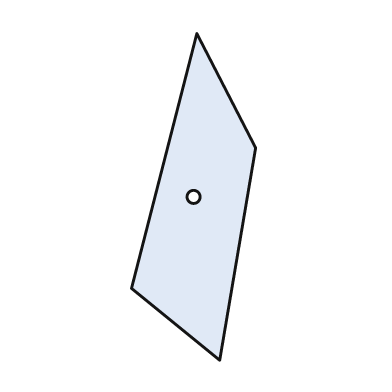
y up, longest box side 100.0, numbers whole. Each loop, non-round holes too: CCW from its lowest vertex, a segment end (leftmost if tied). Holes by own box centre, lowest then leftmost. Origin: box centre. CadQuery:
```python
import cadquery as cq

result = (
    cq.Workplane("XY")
    .moveTo(8.0, -50.0)
    .lineTo(19.0, 15.0)
    .lineTo(1.0, 50.0)
    .lineTo(-19.0, -28.0)
    .close()
    .moveTo(0.0, 0.0)
    .circle(2.0)
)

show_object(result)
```